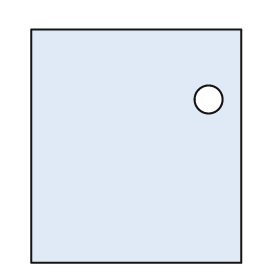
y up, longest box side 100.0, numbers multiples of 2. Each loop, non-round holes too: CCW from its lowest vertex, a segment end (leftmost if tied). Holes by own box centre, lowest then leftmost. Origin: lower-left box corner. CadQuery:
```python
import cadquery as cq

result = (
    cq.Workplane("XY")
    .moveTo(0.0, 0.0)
    .lineTo(90.0, 0.0)
    .lineTo(90.0, 100.0)
    .lineTo(0.0, 100.0)
    .close()
    .moveTo(76.0, 70.0)
    .circle(6.0)
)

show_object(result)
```